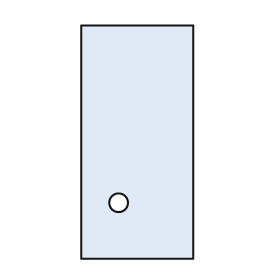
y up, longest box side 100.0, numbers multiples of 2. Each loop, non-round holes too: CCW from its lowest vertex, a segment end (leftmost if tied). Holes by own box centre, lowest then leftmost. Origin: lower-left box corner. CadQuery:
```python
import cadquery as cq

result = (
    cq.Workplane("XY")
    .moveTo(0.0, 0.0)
    .lineTo(48.0, 0.0)
    .lineTo(48.0, 100.0)
    .lineTo(0.0, 100.0)
    .close()
    .moveTo(16.0, 24.0)
    .circle(4.0)
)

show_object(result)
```